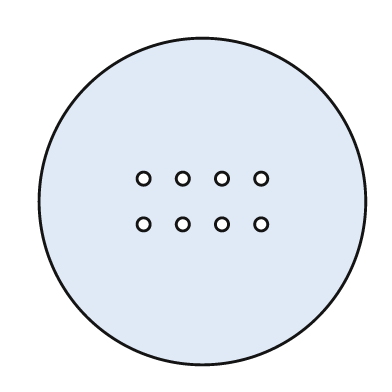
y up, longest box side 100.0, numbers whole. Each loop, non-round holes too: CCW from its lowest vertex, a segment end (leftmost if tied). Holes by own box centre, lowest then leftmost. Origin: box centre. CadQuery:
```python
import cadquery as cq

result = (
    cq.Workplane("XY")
    .moveTo(0.0, 0.0)
    .circle(50.0)
    .moveTo(-18.0, -7.0)
    .circle(2.0)
    .moveTo(-6.0, -7.0)
    .circle(2.0)
    .moveTo(6.0, -7.0)
    .circle(2.0)
    .moveTo(18.0, -7.0)
    .circle(2.0)
    .moveTo(-18.0, 7.0)
    .circle(2.0)
    .moveTo(-6.0, 7.0)
    .circle(2.0)
    .moveTo(6.0, 7.0)
    .circle(2.0)
    .moveTo(18.0, 7.0)
    .circle(2.0)
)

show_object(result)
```